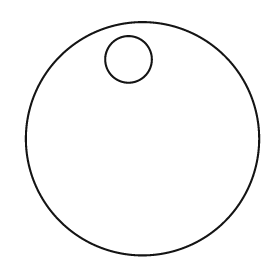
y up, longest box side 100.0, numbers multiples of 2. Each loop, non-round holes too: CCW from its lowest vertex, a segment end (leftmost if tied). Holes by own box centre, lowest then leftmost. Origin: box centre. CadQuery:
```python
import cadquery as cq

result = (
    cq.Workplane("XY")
    .moveTo(0.0, 0.0)
    .circle(50.0)
    .moveTo(-6.0, 34.0)
    .circle(10.0)
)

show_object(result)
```